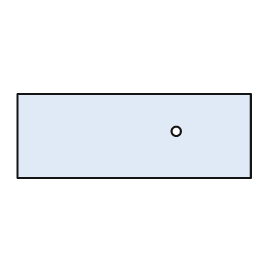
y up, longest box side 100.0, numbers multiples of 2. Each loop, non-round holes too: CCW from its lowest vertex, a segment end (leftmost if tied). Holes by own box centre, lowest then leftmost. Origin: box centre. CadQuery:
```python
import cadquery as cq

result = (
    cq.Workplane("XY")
    .moveTo(-50.0, -18.0)
    .lineTo(50.0, -18.0)
    .lineTo(50.0, 18.0)
    .lineTo(-50.0, 18.0)
    .close()
    .moveTo(18.0, 2.0)
    .circle(2.0)
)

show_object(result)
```